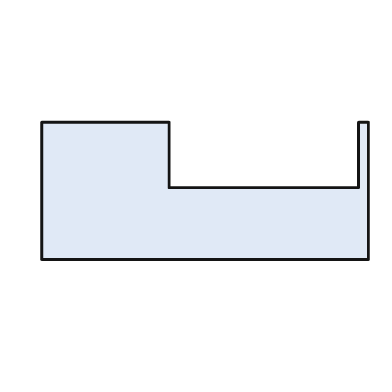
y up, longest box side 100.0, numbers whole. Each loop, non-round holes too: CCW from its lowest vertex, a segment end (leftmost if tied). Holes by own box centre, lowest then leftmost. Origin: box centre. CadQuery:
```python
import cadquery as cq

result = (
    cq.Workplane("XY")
    .moveTo(-50.0, -21.0)
    .lineTo(50.0, -21.0)
    .lineTo(50.0, 21.0)
    .lineTo(47.0, 21.0)
    .lineTo(47.0, 1.0)
    .lineTo(-11.0, 1.0)
    .lineTo(-11.0, 21.0)
    .lineTo(-50.0, 21.0)
    .close()
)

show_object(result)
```